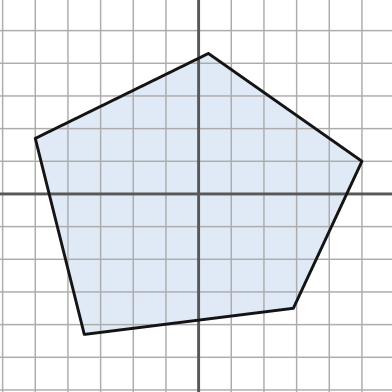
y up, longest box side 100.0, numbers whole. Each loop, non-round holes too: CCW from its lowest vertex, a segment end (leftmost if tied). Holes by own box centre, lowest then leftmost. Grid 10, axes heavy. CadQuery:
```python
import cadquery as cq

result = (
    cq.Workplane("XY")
    .moveTo(-35.0, -43.0)
    .lineTo(29.0, -35.0)
    .lineTo(50.0, 10.0)
    .lineTo(3.0, 43.0)
    .lineTo(-50.0, 17.0)
    .close()
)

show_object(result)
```